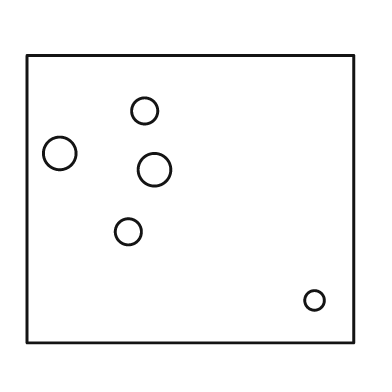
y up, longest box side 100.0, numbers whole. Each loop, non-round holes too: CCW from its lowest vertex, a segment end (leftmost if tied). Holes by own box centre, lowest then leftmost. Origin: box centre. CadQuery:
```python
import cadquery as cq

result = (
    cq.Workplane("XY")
    .moveTo(-50.0, -44.0)
    .lineTo(50.0, -44.0)
    .lineTo(50.0, 44.0)
    .lineTo(-50.0, 44.0)
    .close()
    .moveTo(38.0, -31.0)
    .circle(3.0)
    .moveTo(-19.0, -10.0)
    .circle(4.0)
    .moveTo(-11.0, 9.0)
    .circle(5.0)
    .moveTo(-40.0, 14.0)
    .circle(5.0)
    .moveTo(-14.0, 27.0)
    .circle(4.0)
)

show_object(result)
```